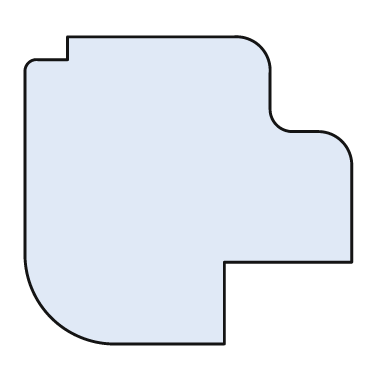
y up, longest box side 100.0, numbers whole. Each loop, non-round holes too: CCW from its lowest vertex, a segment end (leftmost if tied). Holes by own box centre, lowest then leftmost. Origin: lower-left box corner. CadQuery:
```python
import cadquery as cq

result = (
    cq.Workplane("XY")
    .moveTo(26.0, 0.0)
    .lineTo(61.0, 0.0)
    .lineTo(61.0, 25.0)
    .lineTo(100.0, 25.0)
    .lineTo(100.0, 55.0)
    .threePointArc((97.0, 62.0), (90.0, 65.0))
    .lineTo(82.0, 65.0)
    .threePointArc((77.0, 67.0), (75.0, 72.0))
    .lineTo(75.0, 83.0)
    .threePointArc((72.0, 91.0), (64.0, 94.0))
    .lineTo(13.0, 94.0)
    .lineTo(13.0, 87.0)
    .lineTo(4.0, 87.0)
    .threePointArc((1.0, 86.0), (0.0, 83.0))
    .lineTo(0.0, 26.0)
    .threePointArc((8.0, 8.0), (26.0, 0.0))
    .close()
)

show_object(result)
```